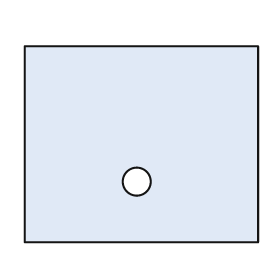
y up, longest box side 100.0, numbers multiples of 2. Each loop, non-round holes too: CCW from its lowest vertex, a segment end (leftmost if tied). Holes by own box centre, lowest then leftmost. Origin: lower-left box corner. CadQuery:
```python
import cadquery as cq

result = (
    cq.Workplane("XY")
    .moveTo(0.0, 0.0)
    .lineTo(100.0, 0.0)
    .lineTo(100.0, 84.0)
    .lineTo(0.0, 84.0)
    .close()
    .moveTo(48.0, 26.0)
    .circle(6.0)
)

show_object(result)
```